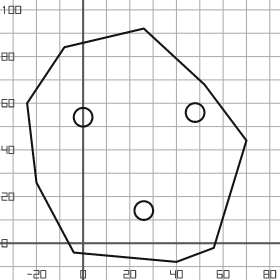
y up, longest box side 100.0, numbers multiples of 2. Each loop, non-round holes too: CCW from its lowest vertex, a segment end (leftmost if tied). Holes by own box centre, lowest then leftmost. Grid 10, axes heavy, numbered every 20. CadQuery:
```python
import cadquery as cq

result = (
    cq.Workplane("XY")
    .moveTo(40.0, -8.0)
    .lineTo(56.0, -2.0)
    .lineTo(70.0, 44.0)
    .lineTo(52.0, 68.0)
    .lineTo(26.0, 92.0)
    .lineTo(-8.0, 84.0)
    .lineTo(-24.0, 60.0)
    .lineTo(-20.0, 26.0)
    .lineTo(-4.0, -4.0)
    .close()
    .moveTo(26.0, 14.0)
    .circle(4.0)
    .moveTo(0.0, 54.0)
    .circle(4.0)
    .moveTo(48.0, 56.0)
    .circle(4.0)
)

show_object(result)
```